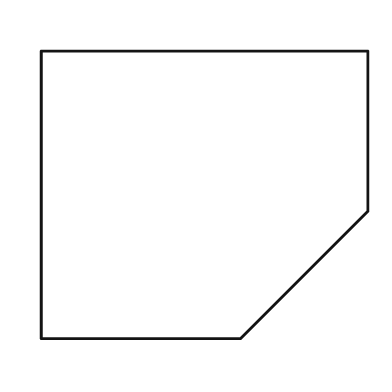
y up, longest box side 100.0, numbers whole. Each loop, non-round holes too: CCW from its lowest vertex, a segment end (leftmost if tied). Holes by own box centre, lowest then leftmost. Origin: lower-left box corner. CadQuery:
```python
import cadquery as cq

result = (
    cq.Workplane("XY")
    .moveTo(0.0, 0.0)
    .lineTo(61.0, 0.0)
    .lineTo(100.0, 39.0)
    .lineTo(100.0, 88.0)
    .lineTo(0.0, 88.0)
    .close()
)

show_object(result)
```